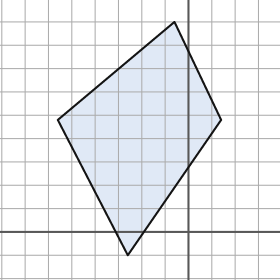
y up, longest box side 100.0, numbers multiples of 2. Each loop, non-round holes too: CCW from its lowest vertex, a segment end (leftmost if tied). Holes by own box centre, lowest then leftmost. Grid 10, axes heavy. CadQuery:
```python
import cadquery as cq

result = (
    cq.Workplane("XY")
    .moveTo(-26.0, -10.0)
    .lineTo(14.0, 48.0)
    .lineTo(-6.0, 90.0)
    .lineTo(-56.0, 48.0)
    .close()
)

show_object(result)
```